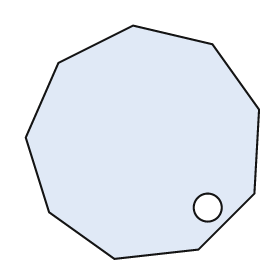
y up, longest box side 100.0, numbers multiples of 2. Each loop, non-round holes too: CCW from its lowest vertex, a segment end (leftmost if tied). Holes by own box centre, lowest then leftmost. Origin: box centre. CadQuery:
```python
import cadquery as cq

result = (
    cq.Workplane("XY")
    .moveTo(-12.0, -50.0)
    .lineTo(24.0, -46.0)
    .lineTo(48.0, -22.0)
    .lineTo(50.0, 14.0)
    .lineTo(30.0, 42.0)
    .lineTo(-4.0, 50.0)
    .lineTo(-36.0, 34.0)
    .lineTo(-50.0, 2.0)
    .lineTo(-40.0, -30.0)
    .close()
    .moveTo(28.0, -28.0)
    .circle(6.0)
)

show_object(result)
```